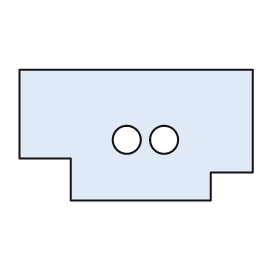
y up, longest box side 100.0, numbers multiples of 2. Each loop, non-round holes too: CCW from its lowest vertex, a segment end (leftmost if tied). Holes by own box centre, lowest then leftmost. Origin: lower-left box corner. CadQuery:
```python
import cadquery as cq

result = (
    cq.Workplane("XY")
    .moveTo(22.0, 0.0)
    .lineTo(82.0, 0.0)
    .lineTo(82.0, 12.0)
    .lineTo(100.0, 12.0)
    .lineTo(100.0, 56.0)
    .lineTo(0.0, 56.0)
    .lineTo(0.0, 18.0)
    .lineTo(22.0, 18.0)
    .close()
    .moveTo(46.0, 26.0)
    .circle(6.0)
    .moveTo(62.0, 26.0)
    .circle(6.0)
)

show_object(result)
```